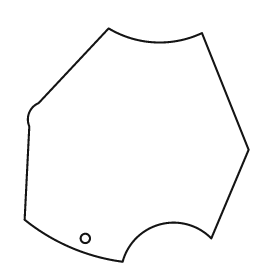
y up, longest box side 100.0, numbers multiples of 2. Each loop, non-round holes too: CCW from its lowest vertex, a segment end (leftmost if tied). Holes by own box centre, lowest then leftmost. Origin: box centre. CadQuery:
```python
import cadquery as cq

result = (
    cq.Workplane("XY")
    .moveTo(-6.0, -50.0)
    .threePointArc((10.0, -34.0), (32.0, -40.0))
    .lineTo(48.0, -2.0)
    .lineTo(28.0, 48.0)
    .threePointArc((8.0, 44.0), (-12.0, 50.0))
    .lineTo(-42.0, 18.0)
    .threePointArc((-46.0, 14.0), (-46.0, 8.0))
    .lineTo(-48.0, -32.0)
    .threePointArc((-28.0, -44.0), (-6.0, -50.0))
    .close()
    .moveTo(-22.0, -40.0)
    .circle(2.0)
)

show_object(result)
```